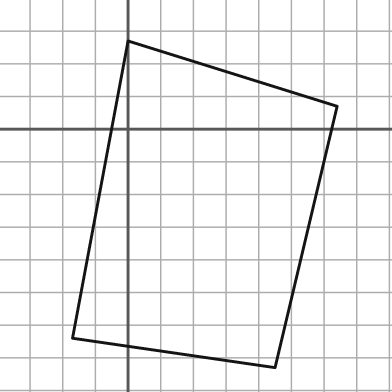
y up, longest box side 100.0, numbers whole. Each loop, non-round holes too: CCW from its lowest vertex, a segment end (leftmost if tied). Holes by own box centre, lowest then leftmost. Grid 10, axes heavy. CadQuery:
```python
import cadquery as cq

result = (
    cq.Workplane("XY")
    .moveTo(45.0, -73.0)
    .lineTo(64.0, 7.0)
    .lineTo(0.0, 27.0)
    .lineTo(-17.0, -64.0)
    .close()
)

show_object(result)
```